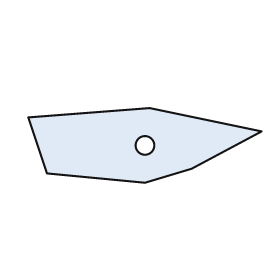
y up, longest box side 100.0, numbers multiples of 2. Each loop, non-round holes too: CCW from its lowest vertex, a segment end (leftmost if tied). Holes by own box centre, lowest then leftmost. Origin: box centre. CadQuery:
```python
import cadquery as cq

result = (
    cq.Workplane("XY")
    .moveTo(0.0, -16.0)
    .lineTo(20.0, -10.0)
    .lineTo(50.0, 6.0)
    .lineTo(2.0, 16.0)
    .lineTo(-50.0, 12.0)
    .lineTo(-42.0, -12.0)
    .close()
    .moveTo(0.0, 0.0)
    .circle(4.0)
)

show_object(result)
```